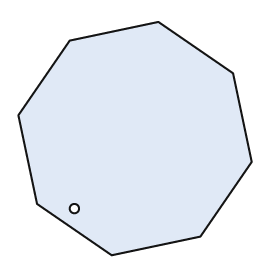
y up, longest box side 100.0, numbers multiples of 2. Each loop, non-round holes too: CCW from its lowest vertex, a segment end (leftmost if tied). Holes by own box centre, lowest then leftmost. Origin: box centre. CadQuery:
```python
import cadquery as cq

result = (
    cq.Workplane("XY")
    .moveTo(-10.0, -50.0)
    .lineTo(28.0, -42.0)
    .lineTo(50.0, -10.0)
    .lineTo(42.0, 28.0)
    .lineTo(10.0, 50.0)
    .lineTo(-28.0, 42.0)
    .lineTo(-50.0, 10.0)
    .lineTo(-42.0, -28.0)
    .close()
    .moveTo(-26.0, -30.0)
    .circle(2.0)
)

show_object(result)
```